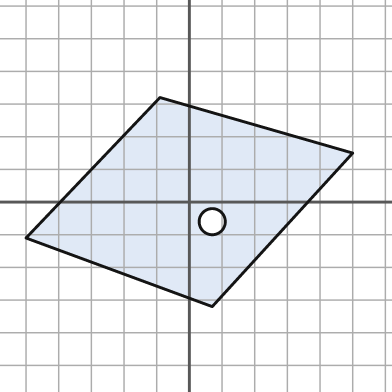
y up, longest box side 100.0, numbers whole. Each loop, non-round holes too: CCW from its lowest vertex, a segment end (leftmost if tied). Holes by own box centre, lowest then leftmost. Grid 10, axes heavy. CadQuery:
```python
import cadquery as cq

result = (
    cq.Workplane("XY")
    .moveTo(7.0, -32.0)
    .lineTo(50.0, 15.0)
    .lineTo(-9.0, 32.0)
    .lineTo(-50.0, -11.0)
    .close()
    .moveTo(7.0, -6.0)
    .circle(4.0)
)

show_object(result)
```